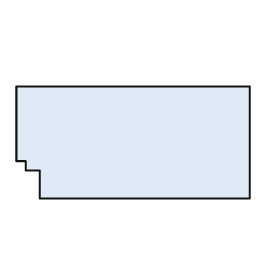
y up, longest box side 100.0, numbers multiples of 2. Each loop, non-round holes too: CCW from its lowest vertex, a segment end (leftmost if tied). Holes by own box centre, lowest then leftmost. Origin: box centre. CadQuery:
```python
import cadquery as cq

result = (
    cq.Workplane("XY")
    .moveTo(-40.0, -24.0)
    .lineTo(50.0, -24.0)
    .lineTo(50.0, 24.0)
    .lineTo(-50.0, 24.0)
    .lineTo(-50.0, -8.0)
    .lineTo(-46.0, -8.0)
    .lineTo(-46.0, -12.0)
    .lineTo(-40.0, -12.0)
    .close()
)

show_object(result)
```